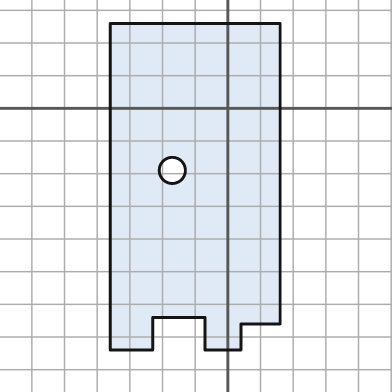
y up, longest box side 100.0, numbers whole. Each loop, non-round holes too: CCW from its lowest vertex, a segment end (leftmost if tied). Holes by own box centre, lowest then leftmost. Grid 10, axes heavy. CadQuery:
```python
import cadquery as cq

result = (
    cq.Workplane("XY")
    .moveTo(-36.0, -74.0)
    .lineTo(-23.0, -74.0)
    .lineTo(-23.0, -64.0)
    .lineTo(-7.0, -64.0)
    .lineTo(-7.0, -74.0)
    .lineTo(4.0, -74.0)
    .lineTo(4.0, -66.0)
    .lineTo(16.0, -66.0)
    .lineTo(16.0, 26.0)
    .lineTo(-36.0, 26.0)
    .close()
    .moveTo(-17.0, -19.0)
    .circle(4.0)
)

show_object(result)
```